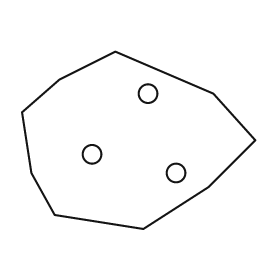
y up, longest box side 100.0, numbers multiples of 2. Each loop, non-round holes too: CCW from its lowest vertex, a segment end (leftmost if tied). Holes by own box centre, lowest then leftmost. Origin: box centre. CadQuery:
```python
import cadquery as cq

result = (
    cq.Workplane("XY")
    .moveTo(2.0, -38.0)
    .lineTo(30.0, -20.0)
    .lineTo(50.0, 0.0)
    .lineTo(32.0, 20.0)
    .lineTo(-10.0, 38.0)
    .lineTo(-34.0, 26.0)
    .lineTo(-50.0, 12.0)
    .lineTo(-46.0, -14.0)
    .lineTo(-36.0, -32.0)
    .close()
    .moveTo(16.0, -14.0)
    .circle(4.0)
    .moveTo(-20.0, -6.0)
    .circle(4.0)
    .moveTo(4.0, 20.0)
    .circle(4.0)
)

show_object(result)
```